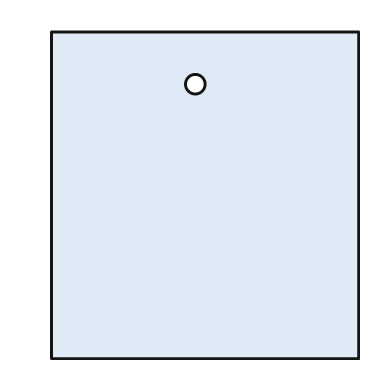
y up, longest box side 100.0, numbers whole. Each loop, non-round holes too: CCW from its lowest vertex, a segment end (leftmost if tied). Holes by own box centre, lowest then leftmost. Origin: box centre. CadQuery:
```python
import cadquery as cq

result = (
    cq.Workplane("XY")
    .moveTo(-47.0, -50.0)
    .lineTo(47.0, -50.0)
    .lineTo(47.0, 50.0)
    .lineTo(-47.0, 50.0)
    .close()
    .moveTo(-3.0, 34.0)
    .circle(3.0)
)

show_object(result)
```